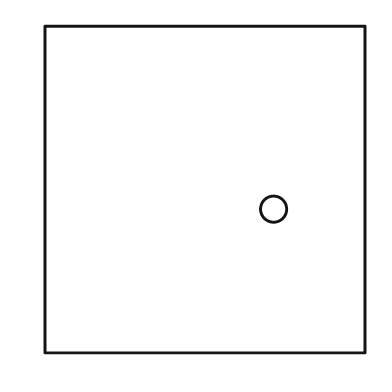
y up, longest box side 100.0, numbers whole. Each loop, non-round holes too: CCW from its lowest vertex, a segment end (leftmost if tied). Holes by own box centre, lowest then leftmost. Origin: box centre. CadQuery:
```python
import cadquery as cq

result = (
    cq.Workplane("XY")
    .moveTo(-49.0, -50.0)
    .lineTo(49.0, -50.0)
    .lineTo(49.0, 50.0)
    .lineTo(-49.0, 50.0)
    .close()
    .moveTo(21.0, -6.0)
    .circle(4.0)
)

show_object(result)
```